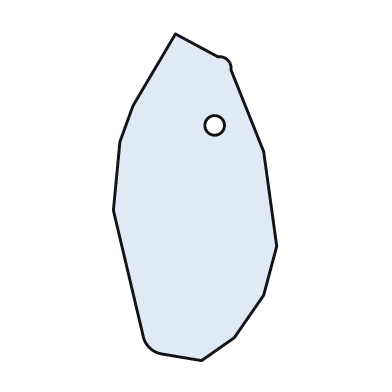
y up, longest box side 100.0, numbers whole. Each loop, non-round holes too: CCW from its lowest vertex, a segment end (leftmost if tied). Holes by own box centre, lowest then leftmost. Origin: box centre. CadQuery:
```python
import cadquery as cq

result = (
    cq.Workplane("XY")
    .moveTo(2.0, -50.0)
    .lineTo(12.0, -43.0)
    .lineTo(21.0, -30.0)
    .lineTo(25.0, -15.0)
    .lineTo(21.0, 14.0)
    .lineTo(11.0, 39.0)
    .threePointArc((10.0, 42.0), (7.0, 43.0))
    .lineTo(-6.0, 50.0)
    .lineTo(-19.0, 28.0)
    .lineTo(-23.0, 17.0)
    .lineTo(-25.0, -4.0)
    .lineTo(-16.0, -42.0)
    .threePointArc((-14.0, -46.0), (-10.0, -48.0))
    .close()
    .moveTo(6.0, 22.0)
    .circle(3.0)
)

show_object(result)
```